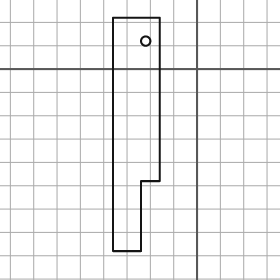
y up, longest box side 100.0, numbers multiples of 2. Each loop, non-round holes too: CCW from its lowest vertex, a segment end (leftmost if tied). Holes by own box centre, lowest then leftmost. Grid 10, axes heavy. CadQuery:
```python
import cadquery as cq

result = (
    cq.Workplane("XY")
    .moveTo(-36.0, -78.0)
    .lineTo(-24.0, -78.0)
    .lineTo(-24.0, -48.0)
    .lineTo(-16.0, -48.0)
    .lineTo(-16.0, 22.0)
    .lineTo(-36.0, 22.0)
    .close()
    .moveTo(-22.0, 12.0)
    .circle(2.0)
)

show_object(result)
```